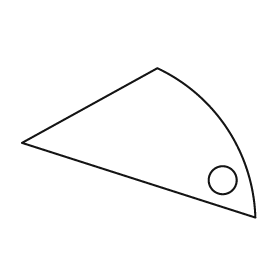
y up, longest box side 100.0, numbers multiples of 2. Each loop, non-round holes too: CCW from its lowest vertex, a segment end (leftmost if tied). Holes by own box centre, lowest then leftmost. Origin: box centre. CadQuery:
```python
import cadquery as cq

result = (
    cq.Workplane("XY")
    .moveTo(50.0, -32.0)
    .threePointArc((38.0, 6.0), (8.0, 32.0))
    .lineTo(-50.0, 0.0)
    .close()
    .moveTo(36.0, -16.0)
    .circle(6.0)
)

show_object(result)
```